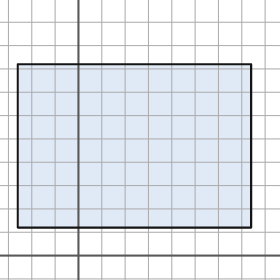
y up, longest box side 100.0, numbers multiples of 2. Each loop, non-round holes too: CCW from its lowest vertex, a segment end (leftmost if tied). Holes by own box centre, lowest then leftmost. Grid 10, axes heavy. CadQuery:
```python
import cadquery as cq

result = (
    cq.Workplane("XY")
    .moveTo(-26.0, 12.0)
    .lineTo(74.0, 12.0)
    .lineTo(74.0, 82.0)
    .lineTo(-26.0, 82.0)
    .close()
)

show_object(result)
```